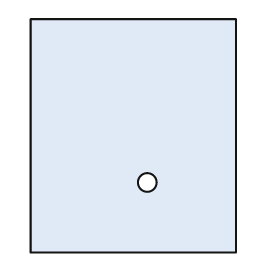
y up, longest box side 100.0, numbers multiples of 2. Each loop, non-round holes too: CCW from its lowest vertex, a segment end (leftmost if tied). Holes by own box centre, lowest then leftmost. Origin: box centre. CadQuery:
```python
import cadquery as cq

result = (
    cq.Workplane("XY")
    .moveTo(-44.0, -50.0)
    .lineTo(44.0, -50.0)
    .lineTo(44.0, 50.0)
    .lineTo(-44.0, 50.0)
    .close()
    .moveTo(6.0, -20.0)
    .circle(4.0)
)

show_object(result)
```